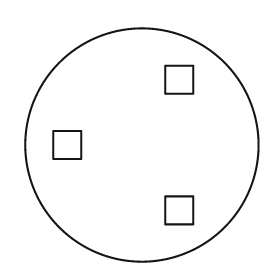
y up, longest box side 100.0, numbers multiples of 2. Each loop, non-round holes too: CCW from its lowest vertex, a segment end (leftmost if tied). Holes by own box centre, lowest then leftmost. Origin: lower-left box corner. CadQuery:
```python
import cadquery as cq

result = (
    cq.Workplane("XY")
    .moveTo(50.0, 50.0)
    .circle(50.0)
    .moveTo(60.0, 16.0)
    .lineTo(72.0, 16.0)
    .lineTo(72.0, 28.0)
    .lineTo(60.0, 28.0)
    .close()
    .moveTo(12.0, 44.0)
    .lineTo(24.0, 44.0)
    .lineTo(24.0, 56.0)
    .lineTo(12.0, 56.0)
    .close()
    .moveTo(60.0, 72.0)
    .lineTo(72.0, 72.0)
    .lineTo(72.0, 84.0)
    .lineTo(60.0, 84.0)
    .close()
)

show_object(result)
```